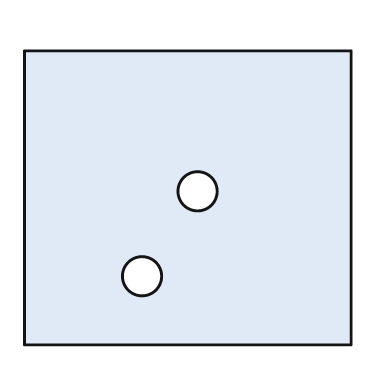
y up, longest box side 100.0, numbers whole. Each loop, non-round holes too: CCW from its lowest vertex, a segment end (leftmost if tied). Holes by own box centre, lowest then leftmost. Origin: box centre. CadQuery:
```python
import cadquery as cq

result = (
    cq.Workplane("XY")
    .moveTo(-50.0, -45.0)
    .lineTo(50.0, -45.0)
    .lineTo(50.0, 45.0)
    .lineTo(-50.0, 45.0)
    .close()
    .moveTo(-14.0, -24.0)
    .circle(6.0)
    .moveTo(3.0, 2.0)
    .circle(6.0)
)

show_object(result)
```